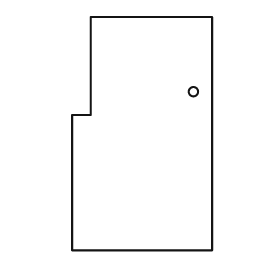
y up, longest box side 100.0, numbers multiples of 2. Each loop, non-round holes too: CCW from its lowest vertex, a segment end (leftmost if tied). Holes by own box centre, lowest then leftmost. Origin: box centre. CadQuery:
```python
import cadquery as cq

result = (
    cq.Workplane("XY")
    .moveTo(-30.0, -50.0)
    .lineTo(30.0, -50.0)
    .lineTo(30.0, 50.0)
    .lineTo(-22.0, 50.0)
    .lineTo(-22.0, 8.0)
    .lineTo(-30.0, 8.0)
    .close()
    .moveTo(22.0, 18.0)
    .circle(2.0)
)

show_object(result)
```